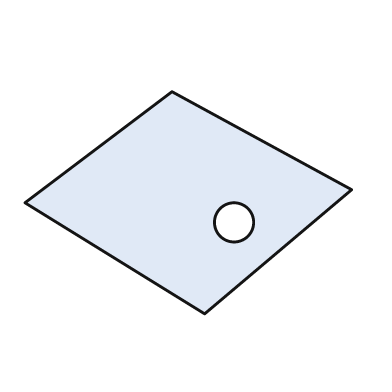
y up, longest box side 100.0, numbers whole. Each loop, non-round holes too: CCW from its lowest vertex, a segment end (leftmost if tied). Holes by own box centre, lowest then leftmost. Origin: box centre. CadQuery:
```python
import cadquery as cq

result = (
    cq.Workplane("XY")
    .moveTo(5.0, -34.0)
    .lineTo(50.0, 4.0)
    .lineTo(-5.0, 34.0)
    .lineTo(-50.0, 0.0)
    .close()
    .moveTo(14.0, -6.0)
    .circle(6.0)
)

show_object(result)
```